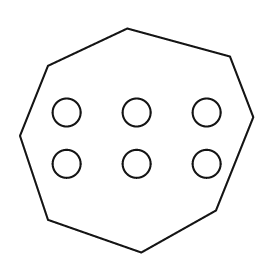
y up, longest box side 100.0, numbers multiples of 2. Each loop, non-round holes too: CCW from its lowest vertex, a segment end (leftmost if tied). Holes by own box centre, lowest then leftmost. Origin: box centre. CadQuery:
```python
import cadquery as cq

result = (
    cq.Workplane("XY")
    .moveTo(2.0, -48.0)
    .lineTo(34.0, -30.0)
    .lineTo(50.0, 10.0)
    .lineTo(40.0, 36.0)
    .lineTo(-4.0, 48.0)
    .lineTo(-38.0, 32.0)
    .lineTo(-50.0, 2.0)
    .lineTo(-38.0, -34.0)
    .close()
    .moveTo(-30.0, -10.0)
    .circle(6.0)
    .moveTo(0.0, -10.0)
    .circle(6.0)
    .moveTo(30.0, -10.0)
    .circle(6.0)
    .moveTo(-30.0, 12.0)
    .circle(6.0)
    .moveTo(0.0, 12.0)
    .circle(6.0)
    .moveTo(30.0, 12.0)
    .circle(6.0)
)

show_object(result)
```